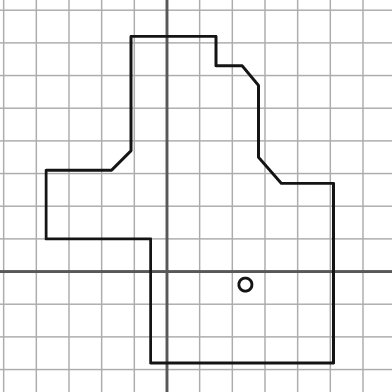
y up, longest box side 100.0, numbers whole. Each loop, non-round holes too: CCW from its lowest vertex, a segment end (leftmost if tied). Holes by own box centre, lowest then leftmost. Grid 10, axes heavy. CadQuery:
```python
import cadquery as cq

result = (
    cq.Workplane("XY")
    .moveTo(-5.0, -28.0)
    .lineTo(51.0, -28.0)
    .lineTo(51.0, 27.0)
    .lineTo(35.0, 27.0)
    .lineTo(28.0, 35.0)
    .lineTo(28.0, 57.0)
    .lineTo(23.0, 63.0)
    .lineTo(15.0, 63.0)
    .lineTo(15.0, 72.0)
    .lineTo(-11.0, 72.0)
    .lineTo(-11.0, 37.0)
    .lineTo(-17.0, 31.0)
    .lineTo(-37.0, 31.0)
    .lineTo(-37.0, 10.0)
    .lineTo(-5.0, 10.0)
    .close()
    .moveTo(24.0, -4.0)
    .circle(2.0)
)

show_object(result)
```